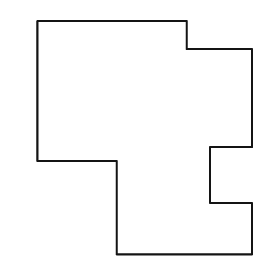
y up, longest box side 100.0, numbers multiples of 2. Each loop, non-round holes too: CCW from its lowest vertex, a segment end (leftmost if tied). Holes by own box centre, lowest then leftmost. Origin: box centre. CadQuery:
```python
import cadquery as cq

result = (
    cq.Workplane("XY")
    .moveTo(-12.0, -50.0)
    .lineTo(46.0, -50.0)
    .lineTo(46.0, -28.0)
    .lineTo(28.0, -28.0)
    .lineTo(28.0, -4.0)
    .lineTo(46.0, -4.0)
    .lineTo(46.0, 38.0)
    .lineTo(18.0, 38.0)
    .lineTo(18.0, 50.0)
    .lineTo(-46.0, 50.0)
    .lineTo(-46.0, -10.0)
    .lineTo(-12.0, -10.0)
    .close()
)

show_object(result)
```